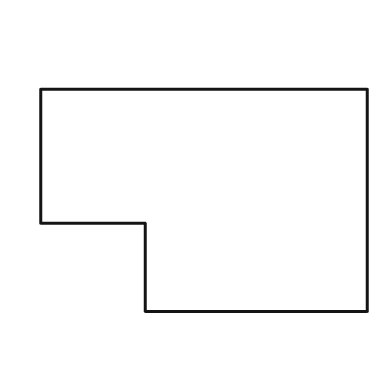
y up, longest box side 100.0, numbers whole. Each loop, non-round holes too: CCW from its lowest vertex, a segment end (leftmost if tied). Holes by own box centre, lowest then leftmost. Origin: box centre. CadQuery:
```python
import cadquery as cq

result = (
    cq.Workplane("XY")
    .moveTo(-18.0, -34.0)
    .lineTo(50.0, -34.0)
    .lineTo(50.0, 34.0)
    .lineTo(-50.0, 34.0)
    .lineTo(-50.0, -7.0)
    .lineTo(-18.0, -7.0)
    .close()
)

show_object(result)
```